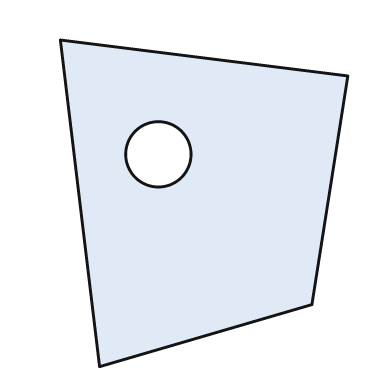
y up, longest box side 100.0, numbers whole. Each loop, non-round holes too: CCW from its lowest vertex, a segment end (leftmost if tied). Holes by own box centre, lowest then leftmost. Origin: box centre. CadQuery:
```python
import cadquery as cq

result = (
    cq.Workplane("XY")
    .moveTo(-32.0, -50.0)
    .lineTo(33.0, -31.0)
    .lineTo(44.0, 39.0)
    .lineTo(-44.0, 50.0)
    .close()
    .moveTo(-14.0, 15.0)
    .circle(10.0)
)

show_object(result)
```